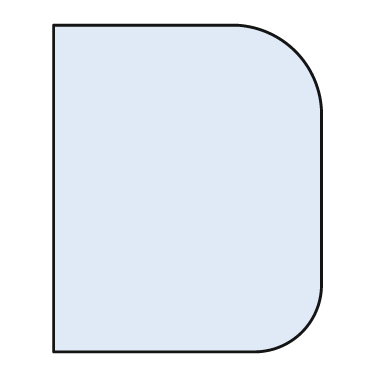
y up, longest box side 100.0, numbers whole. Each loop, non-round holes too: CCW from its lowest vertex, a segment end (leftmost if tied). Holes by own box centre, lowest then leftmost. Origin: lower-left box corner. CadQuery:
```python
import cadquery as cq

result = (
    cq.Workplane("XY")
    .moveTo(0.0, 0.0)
    .lineTo(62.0, 0.0)
    .threePointArc((76.0, 6.0), (82.0, 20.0))
    .lineTo(82.0, 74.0)
    .threePointArc((74.0, 92.0), (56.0, 100.0))
    .lineTo(0.0, 100.0)
    .close()
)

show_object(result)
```